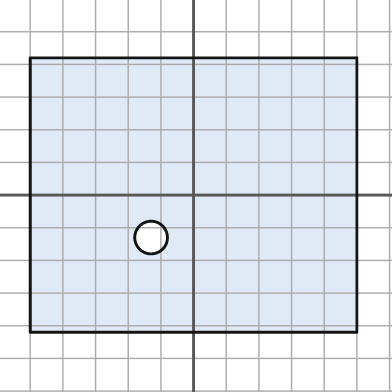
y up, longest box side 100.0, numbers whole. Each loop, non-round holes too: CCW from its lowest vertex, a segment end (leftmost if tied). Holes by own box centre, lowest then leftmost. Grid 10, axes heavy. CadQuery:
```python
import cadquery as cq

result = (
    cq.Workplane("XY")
    .moveTo(-50.0, -42.0)
    .lineTo(50.0, -42.0)
    .lineTo(50.0, 42.0)
    .lineTo(-50.0, 42.0)
    .close()
    .moveTo(-13.0, -13.0)
    .circle(5.0)
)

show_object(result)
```